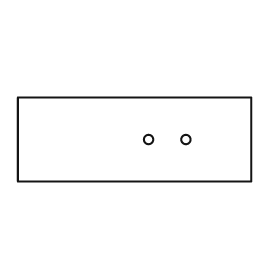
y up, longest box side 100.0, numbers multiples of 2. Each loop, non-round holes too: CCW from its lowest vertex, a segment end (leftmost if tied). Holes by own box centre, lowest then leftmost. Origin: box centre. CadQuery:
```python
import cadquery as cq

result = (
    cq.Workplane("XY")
    .moveTo(-50.0, -18.0)
    .lineTo(50.0, -18.0)
    .lineTo(50.0, 18.0)
    .lineTo(-50.0, 18.0)
    .close()
    .moveTo(6.0, 0.0)
    .circle(2.0)
    .moveTo(22.0, 0.0)
    .circle(2.0)
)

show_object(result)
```